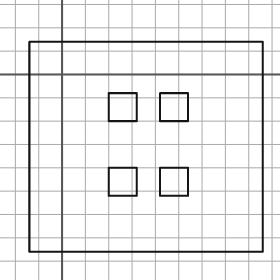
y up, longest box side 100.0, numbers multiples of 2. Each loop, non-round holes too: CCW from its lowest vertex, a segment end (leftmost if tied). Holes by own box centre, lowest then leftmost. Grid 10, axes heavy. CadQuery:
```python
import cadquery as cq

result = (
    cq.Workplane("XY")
    .moveTo(-14.0, -76.0)
    .lineTo(86.0, -76.0)
    .lineTo(86.0, 14.0)
    .lineTo(-14.0, 14.0)
    .close()
    .moveTo(20.0, -52.0)
    .lineTo(32.0, -52.0)
    .lineTo(32.0, -40.0)
    .lineTo(20.0, -40.0)
    .close()
    .moveTo(42.0, -52.0)
    .lineTo(54.0, -52.0)
    .lineTo(54.0, -40.0)
    .lineTo(42.0, -40.0)
    .close()
    .moveTo(20.0, -20.0)
    .lineTo(32.0, -20.0)
    .lineTo(32.0, -8.0)
    .lineTo(20.0, -8.0)
    .close()
    .moveTo(42.0, -20.0)
    .lineTo(54.0, -20.0)
    .lineTo(54.0, -8.0)
    .lineTo(42.0, -8.0)
    .close()
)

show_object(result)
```